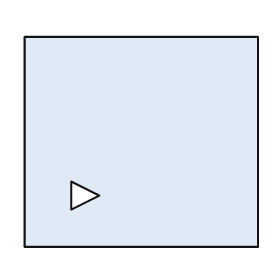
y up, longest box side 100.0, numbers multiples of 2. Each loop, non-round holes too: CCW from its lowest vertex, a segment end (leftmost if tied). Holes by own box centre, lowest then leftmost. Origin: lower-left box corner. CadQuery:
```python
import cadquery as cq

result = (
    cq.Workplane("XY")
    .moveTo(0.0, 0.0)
    .lineTo(100.0, 0.0)
    .lineTo(100.0, 90.0)
    .lineTo(0.0, 90.0)
    .close()
    .moveTo(20.0, 16.0)
    .lineTo(32.0, 22.0)
    .lineTo(20.0, 28.0)
    .close()
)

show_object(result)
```